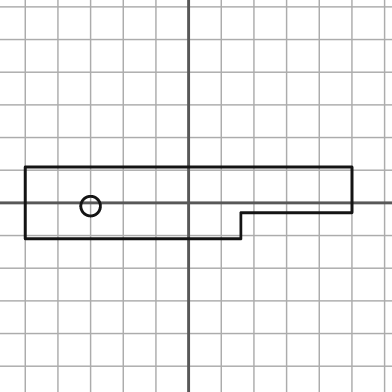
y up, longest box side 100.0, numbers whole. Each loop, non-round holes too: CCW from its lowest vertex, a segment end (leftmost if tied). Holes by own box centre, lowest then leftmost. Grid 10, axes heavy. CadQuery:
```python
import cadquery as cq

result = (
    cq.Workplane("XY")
    .moveTo(-50.0, -11.0)
    .lineTo(16.0, -11.0)
    .lineTo(16.0, -3.0)
    .lineTo(50.0, -3.0)
    .lineTo(50.0, 11.0)
    .lineTo(-50.0, 11.0)
    .close()
    .moveTo(-30.0, -1.0)
    .circle(3.0)
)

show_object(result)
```